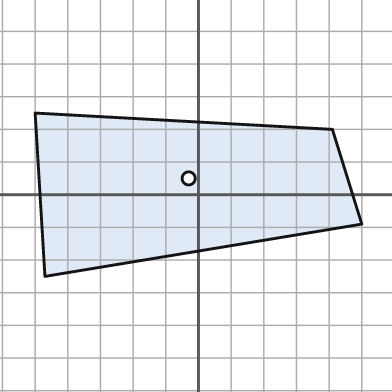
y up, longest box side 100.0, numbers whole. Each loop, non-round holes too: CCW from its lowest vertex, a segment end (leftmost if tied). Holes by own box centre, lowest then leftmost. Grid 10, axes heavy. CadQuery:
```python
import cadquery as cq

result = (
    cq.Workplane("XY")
    .moveTo(-47.0, -25.0)
    .lineTo(50.0, -9.0)
    .lineTo(41.0, 20.0)
    .lineTo(-50.0, 25.0)
    .close()
    .moveTo(-3.0, 5.0)
    .circle(2.0)
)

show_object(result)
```